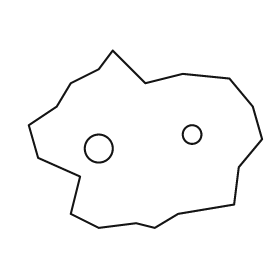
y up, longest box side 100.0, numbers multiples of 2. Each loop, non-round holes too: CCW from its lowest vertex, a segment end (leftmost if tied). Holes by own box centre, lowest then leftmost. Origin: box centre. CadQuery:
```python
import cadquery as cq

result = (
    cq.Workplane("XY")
    .moveTo(-20.0, -38.0)
    .lineTo(-4.0, -36.0)
    .lineTo(4.0, -38.0)
    .lineTo(14.0, -32.0)
    .lineTo(38.0, -28.0)
    .lineTo(40.0, -12.0)
    .lineTo(50.0, 0.0)
    .lineTo(46.0, 14.0)
    .lineTo(36.0, 26.0)
    .lineTo(16.0, 28.0)
    .lineTo(0.0, 24.0)
    .lineTo(-14.0, 38.0)
    .lineTo(-20.0, 30.0)
    .lineTo(-32.0, 24.0)
    .lineTo(-38.0, 14.0)
    .lineTo(-50.0, 6.0)
    .lineTo(-46.0, -8.0)
    .lineTo(-28.0, -16.0)
    .lineTo(-32.0, -32.0)
    .close()
    .moveTo(-20.0, -4.0)
    .circle(6.0)
    .moveTo(20.0, 2.0)
    .circle(4.0)
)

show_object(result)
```